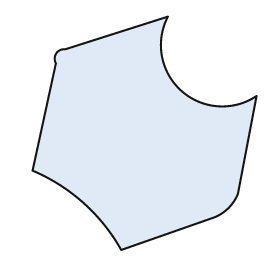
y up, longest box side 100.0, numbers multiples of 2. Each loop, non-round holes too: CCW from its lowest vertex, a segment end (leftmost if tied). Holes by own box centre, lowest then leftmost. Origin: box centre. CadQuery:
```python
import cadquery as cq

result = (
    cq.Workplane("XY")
    .moveTo(-10.0, -50.0)
    .lineTo(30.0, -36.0)
    .threePointArc((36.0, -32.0), (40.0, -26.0))
    .lineTo(48.0, 16.0)
    .threePointArc((16.0, 18.0), (10.0, 50.0))
    .lineTo(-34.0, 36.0)
    .threePointArc((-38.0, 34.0), (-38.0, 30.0))
    .lineTo(-48.0, -16.0)
    .threePointArc((-26.0, -30.0), (-10.0, -50.0))
    .close()
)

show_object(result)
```